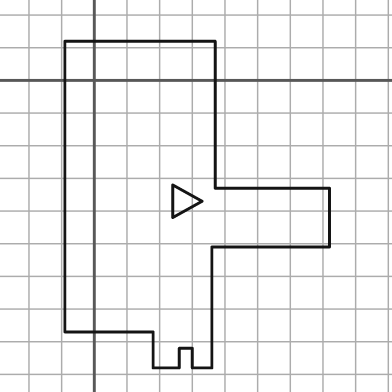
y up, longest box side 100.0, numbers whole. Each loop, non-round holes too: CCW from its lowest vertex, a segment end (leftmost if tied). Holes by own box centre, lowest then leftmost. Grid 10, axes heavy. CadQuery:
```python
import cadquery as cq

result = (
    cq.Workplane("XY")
    .moveTo(18.0, -88.0)
    .lineTo(26.0, -88.0)
    .lineTo(26.0, -82.0)
    .lineTo(30.0, -82.0)
    .lineTo(30.0, -88.0)
    .lineTo(36.0, -88.0)
    .lineTo(36.0, -51.0)
    .lineTo(72.0, -51.0)
    .lineTo(72.0, -33.0)
    .lineTo(37.0, -33.0)
    .lineTo(37.0, 12.0)
    .lineTo(-9.0, 12.0)
    .lineTo(-9.0, -77.0)
    .lineTo(18.0, -77.0)
    .close()
    .moveTo(24.0, -42.0)
    .lineTo(33.0, -37.0)
    .lineTo(24.0, -32.0)
    .close()
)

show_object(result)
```